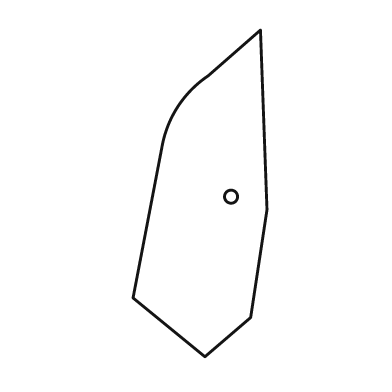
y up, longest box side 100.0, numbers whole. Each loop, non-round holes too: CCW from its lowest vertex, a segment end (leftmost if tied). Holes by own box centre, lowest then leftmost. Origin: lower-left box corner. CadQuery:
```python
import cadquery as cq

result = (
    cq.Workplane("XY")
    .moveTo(22.0, 0.0)
    .lineTo(36.0, 12.0)
    .lineTo(41.0, 45.0)
    .lineTo(39.0, 100.0)
    .lineTo(23.0, 86.0)
    .threePointArc((14.0, 77.0), (9.0, 65.0))
    .lineTo(0.0, 18.0)
    .close()
    .moveTo(30.0, 49.0)
    .circle(2.0)
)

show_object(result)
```